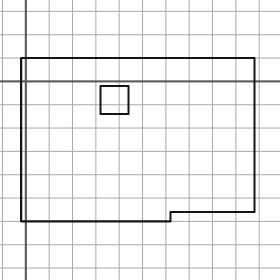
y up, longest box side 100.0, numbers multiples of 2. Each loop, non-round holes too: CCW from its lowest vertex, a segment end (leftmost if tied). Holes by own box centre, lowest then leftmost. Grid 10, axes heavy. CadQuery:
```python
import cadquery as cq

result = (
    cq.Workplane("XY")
    .moveTo(-2.0, -60.0)
    .lineTo(62.0, -60.0)
    .lineTo(62.0, -56.0)
    .lineTo(98.0, -56.0)
    .lineTo(98.0, 10.0)
    .lineTo(-2.0, 10.0)
    .close()
    .moveTo(32.0, -14.0)
    .lineTo(44.0, -14.0)
    .lineTo(44.0, -2.0)
    .lineTo(32.0, -2.0)
    .close()
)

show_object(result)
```